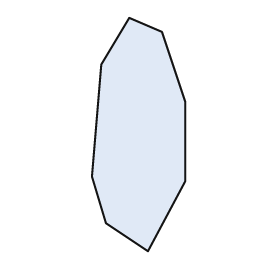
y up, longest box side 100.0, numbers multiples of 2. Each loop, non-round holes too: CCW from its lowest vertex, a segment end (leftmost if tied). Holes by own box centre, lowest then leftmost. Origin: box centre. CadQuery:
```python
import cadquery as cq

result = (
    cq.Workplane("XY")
    .moveTo(4.0, -50.0)
    .lineTo(20.0, -20.0)
    .lineTo(20.0, 14.0)
    .lineTo(10.0, 44.0)
    .lineTo(-4.0, 50.0)
    .lineTo(-16.0, 30.0)
    .lineTo(-20.0, -18.0)
    .lineTo(-14.0, -38.0)
    .close()
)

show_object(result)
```